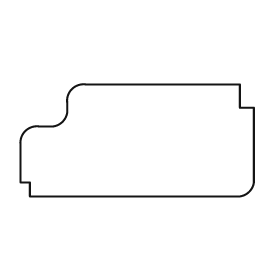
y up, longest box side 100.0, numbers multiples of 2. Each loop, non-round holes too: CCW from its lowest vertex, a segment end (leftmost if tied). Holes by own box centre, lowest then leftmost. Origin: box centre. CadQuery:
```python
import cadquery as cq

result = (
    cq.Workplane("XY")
    .moveTo(-46.0, -24.0)
    .lineTo(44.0, -24.0)
    .threePointArc((48.0, -22.0), (50.0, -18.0))
    .lineTo(50.0, 14.0)
    .lineTo(44.0, 14.0)
    .lineTo(44.0, 24.0)
    .lineTo(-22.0, 24.0)
    .threePointArc((-28.0, 22.0), (-30.0, 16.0))
    .lineTo(-30.0, 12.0)
    .threePointArc((-32.0, 8.0), (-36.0, 6.0))
    .lineTo(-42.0, 6.0)
    .threePointArc((-48.0, 4.0), (-50.0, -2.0))
    .lineTo(-50.0, -18.0)
    .lineTo(-46.0, -18.0)
    .close()
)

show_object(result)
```